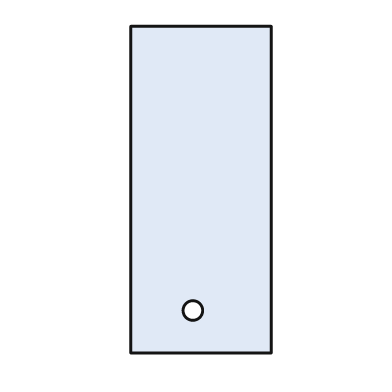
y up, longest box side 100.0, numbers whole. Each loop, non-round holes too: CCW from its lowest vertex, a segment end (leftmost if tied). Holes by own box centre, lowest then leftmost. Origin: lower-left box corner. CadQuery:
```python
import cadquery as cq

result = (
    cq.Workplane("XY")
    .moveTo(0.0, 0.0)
    .lineTo(43.0, 0.0)
    .lineTo(43.0, 100.0)
    .lineTo(0.0, 100.0)
    .close()
    .moveTo(19.0, 13.0)
    .circle(3.0)
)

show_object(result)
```